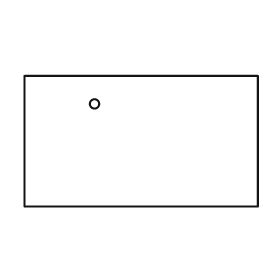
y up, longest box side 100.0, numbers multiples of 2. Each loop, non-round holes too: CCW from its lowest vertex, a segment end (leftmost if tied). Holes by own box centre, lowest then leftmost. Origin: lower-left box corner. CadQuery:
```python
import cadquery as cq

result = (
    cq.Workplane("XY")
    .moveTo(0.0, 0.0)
    .lineTo(100.0, 0.0)
    .lineTo(100.0, 56.0)
    .lineTo(0.0, 56.0)
    .close()
    .moveTo(30.0, 44.0)
    .circle(2.0)
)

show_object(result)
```